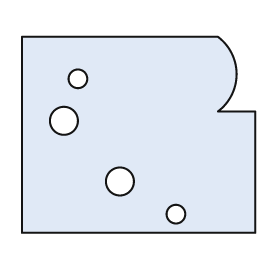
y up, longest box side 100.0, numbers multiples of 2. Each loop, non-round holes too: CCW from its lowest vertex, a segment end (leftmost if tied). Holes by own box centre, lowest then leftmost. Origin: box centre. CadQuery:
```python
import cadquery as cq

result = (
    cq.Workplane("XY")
    .moveTo(-50.0, -42.0)
    .lineTo(50.0, -42.0)
    .lineTo(50.0, 10.0)
    .lineTo(34.0, 10.0)
    .threePointArc((42.0, 26.0), (34.0, 42.0))
    .lineTo(-50.0, 42.0)
    .close()
    .moveTo(16.0, -34.0)
    .circle(4.0)
    .moveTo(-8.0, -20.0)
    .circle(6.0)
    .moveTo(-32.0, 6.0)
    .circle(6.0)
    .moveTo(-26.0, 24.0)
    .circle(4.0)
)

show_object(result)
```